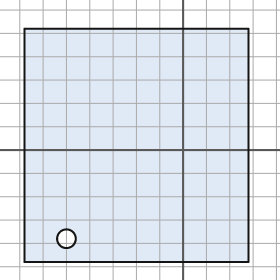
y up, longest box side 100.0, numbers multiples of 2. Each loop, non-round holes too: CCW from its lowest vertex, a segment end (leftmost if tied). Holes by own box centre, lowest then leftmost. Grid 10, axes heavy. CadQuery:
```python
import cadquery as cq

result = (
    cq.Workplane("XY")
    .moveTo(-68.0, -48.0)
    .lineTo(28.0, -48.0)
    .lineTo(28.0, 52.0)
    .lineTo(-68.0, 52.0)
    .close()
    .moveTo(-50.0, -38.0)
    .circle(4.0)
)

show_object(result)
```